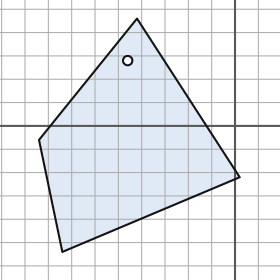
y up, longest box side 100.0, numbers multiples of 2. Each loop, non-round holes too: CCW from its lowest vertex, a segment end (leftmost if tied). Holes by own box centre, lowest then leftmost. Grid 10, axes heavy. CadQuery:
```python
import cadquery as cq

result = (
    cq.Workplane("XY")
    .moveTo(-74.0, -54.0)
    .lineTo(2.0, -22.0)
    .lineTo(-42.0, 46.0)
    .lineTo(-84.0, -6.0)
    .close()
    .moveTo(-46.0, 28.0)
    .circle(2.0)
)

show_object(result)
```